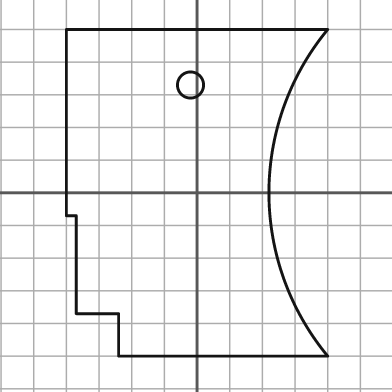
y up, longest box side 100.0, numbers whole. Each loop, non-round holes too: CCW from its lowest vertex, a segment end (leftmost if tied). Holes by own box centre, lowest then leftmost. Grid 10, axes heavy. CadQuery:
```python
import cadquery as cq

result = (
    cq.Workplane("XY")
    .moveTo(-24.0, -50.0)
    .lineTo(40.0, -50.0)
    .threePointArc((22.0, 0.0), (40.0, 50.0))
    .lineTo(-40.0, 50.0)
    .lineTo(-40.0, -7.0)
    .lineTo(-37.0, -7.0)
    .lineTo(-37.0, -37.0)
    .lineTo(-24.0, -37.0)
    .close()
    .moveTo(-2.0, 33.0)
    .circle(4.0)
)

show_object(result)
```